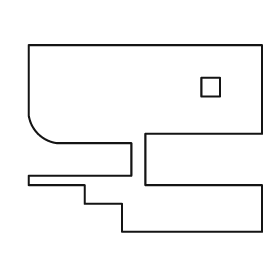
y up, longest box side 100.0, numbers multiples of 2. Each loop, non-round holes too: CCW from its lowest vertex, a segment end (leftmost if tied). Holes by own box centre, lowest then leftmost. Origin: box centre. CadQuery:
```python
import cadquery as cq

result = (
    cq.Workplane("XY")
    .moveTo(-10.0, -40.0)
    .lineTo(50.0, -40.0)
    .lineTo(50.0, -20.0)
    .lineTo(0.0, -20.0)
    .lineTo(0.0, 2.0)
    .lineTo(50.0, 2.0)
    .lineTo(50.0, 40.0)
    .lineTo(-50.0, 40.0)
    .lineTo(-50.0, 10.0)
    .threePointArc((-46.0, 2.0), (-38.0, -2.0))
    .lineTo(-6.0, -2.0)
    .lineTo(-6.0, -16.0)
    .lineTo(-50.0, -16.0)
    .lineTo(-50.0, -20.0)
    .lineTo(-26.0, -20.0)
    .lineTo(-26.0, -28.0)
    .lineTo(-10.0, -28.0)
    .close()
    .moveTo(24.0, 18.0)
    .lineTo(32.0, 18.0)
    .lineTo(32.0, 26.0)
    .lineTo(24.0, 26.0)
    .close()
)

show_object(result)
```